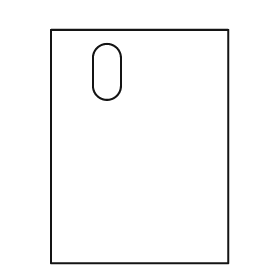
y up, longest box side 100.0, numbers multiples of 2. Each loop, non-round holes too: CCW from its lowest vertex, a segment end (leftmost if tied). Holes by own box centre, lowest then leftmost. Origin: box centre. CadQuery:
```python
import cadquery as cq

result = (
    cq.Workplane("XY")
    .moveTo(-38.0, -50.0)
    .lineTo(38.0, -50.0)
    .lineTo(38.0, 50.0)
    .lineTo(-38.0, 50.0)
    .close()
    .moveTo(-20.0, 26.0)
    .threePointArc((-14.0, 20.0), (-8.0, 26.0))
    .lineTo(-8.0, 38.0)
    .threePointArc((-14.0, 44.0), (-20.0, 38.0))
    .close()
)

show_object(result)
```